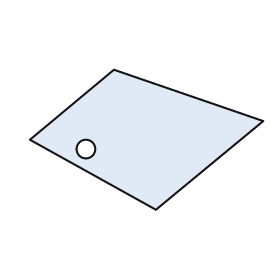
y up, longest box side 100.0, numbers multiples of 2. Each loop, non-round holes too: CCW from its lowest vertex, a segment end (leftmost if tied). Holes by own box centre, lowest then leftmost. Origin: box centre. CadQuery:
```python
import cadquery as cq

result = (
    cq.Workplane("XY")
    .moveTo(4.0, -30.0)
    .lineTo(50.0, 8.0)
    .lineTo(-14.0, 30.0)
    .lineTo(-50.0, 0.0)
    .close()
    .moveTo(-26.0, -4.0)
    .circle(4.0)
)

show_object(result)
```